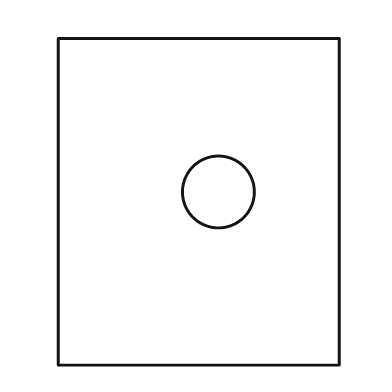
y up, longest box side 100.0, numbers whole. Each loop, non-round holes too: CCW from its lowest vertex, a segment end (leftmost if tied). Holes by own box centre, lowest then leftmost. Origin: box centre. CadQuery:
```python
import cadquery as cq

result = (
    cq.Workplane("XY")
    .moveTo(-43.0, -50.0)
    .lineTo(43.0, -50.0)
    .lineTo(43.0, 50.0)
    .lineTo(-43.0, 50.0)
    .close()
    .moveTo(6.0, 3.0)
    .circle(11.0)
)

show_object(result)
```